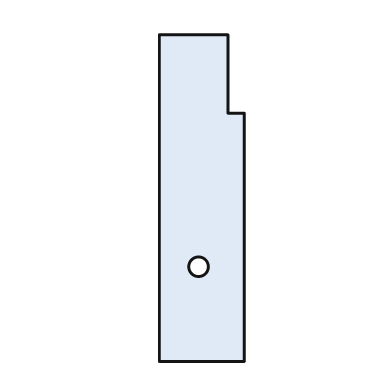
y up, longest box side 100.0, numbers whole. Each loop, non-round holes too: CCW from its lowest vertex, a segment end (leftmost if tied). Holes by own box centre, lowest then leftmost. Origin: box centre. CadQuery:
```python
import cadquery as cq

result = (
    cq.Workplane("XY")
    .moveTo(-13.0, -50.0)
    .lineTo(13.0, -50.0)
    .lineTo(13.0, 26.0)
    .lineTo(8.0, 26.0)
    .lineTo(8.0, 50.0)
    .lineTo(-13.0, 50.0)
    .close()
    .moveTo(-1.0, -21.0)
    .circle(3.0)
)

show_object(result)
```